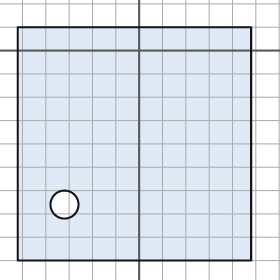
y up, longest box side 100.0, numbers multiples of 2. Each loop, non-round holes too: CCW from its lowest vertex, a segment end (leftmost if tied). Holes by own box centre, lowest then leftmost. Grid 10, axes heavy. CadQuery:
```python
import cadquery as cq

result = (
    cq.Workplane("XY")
    .moveTo(-52.0, -90.0)
    .lineTo(48.0, -90.0)
    .lineTo(48.0, 10.0)
    .lineTo(-52.0, 10.0)
    .close()
    .moveTo(-32.0, -66.0)
    .circle(6.0)
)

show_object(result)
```